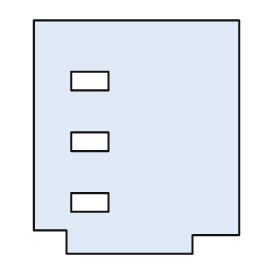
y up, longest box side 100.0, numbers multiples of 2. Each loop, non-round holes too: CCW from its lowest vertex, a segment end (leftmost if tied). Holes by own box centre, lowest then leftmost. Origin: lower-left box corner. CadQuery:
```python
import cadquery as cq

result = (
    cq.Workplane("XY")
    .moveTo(14.0, 0.0)
    .lineTo(68.0, 0.0)
    .lineTo(68.0, 8.0)
    .lineTo(88.0, 8.0)
    .lineTo(88.0, 100.0)
    .lineTo(0.0, 100.0)
    .lineTo(0.0, 10.0)
    .lineTo(14.0, 10.0)
    .close()
    .moveTo(16.0, 18.0)
    .lineTo(32.0, 18.0)
    .lineTo(32.0, 26.0)
    .lineTo(16.0, 26.0)
    .close()
    .moveTo(16.0, 44.0)
    .lineTo(32.0, 44.0)
    .lineTo(32.0, 52.0)
    .lineTo(16.0, 52.0)
    .close()
    .moveTo(16.0, 70.0)
    .lineTo(32.0, 70.0)
    .lineTo(32.0, 78.0)
    .lineTo(16.0, 78.0)
    .close()
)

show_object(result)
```